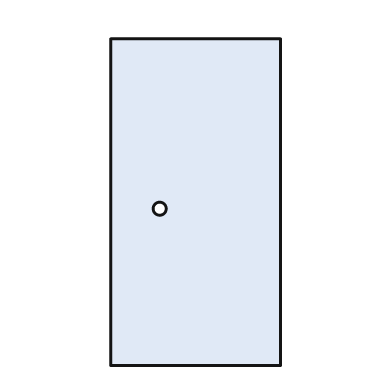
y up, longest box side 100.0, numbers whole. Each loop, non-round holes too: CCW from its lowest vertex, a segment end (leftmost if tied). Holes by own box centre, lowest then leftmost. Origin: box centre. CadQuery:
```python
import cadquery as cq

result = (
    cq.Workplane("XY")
    .moveTo(-26.0, -50.0)
    .lineTo(26.0, -50.0)
    .lineTo(26.0, 50.0)
    .lineTo(-26.0, 50.0)
    .close()
    .moveTo(-11.0, -2.0)
    .circle(2.0)
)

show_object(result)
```